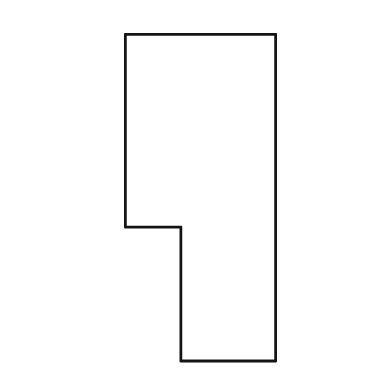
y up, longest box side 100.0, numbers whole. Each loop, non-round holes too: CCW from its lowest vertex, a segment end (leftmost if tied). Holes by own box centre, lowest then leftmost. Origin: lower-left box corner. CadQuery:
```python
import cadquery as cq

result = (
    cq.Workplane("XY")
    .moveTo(17.0, 0.0)
    .lineTo(46.0, 0.0)
    .lineTo(46.0, 100.0)
    .lineTo(0.0, 100.0)
    .lineTo(0.0, 41.0)
    .lineTo(17.0, 41.0)
    .close()
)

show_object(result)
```